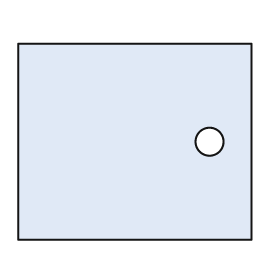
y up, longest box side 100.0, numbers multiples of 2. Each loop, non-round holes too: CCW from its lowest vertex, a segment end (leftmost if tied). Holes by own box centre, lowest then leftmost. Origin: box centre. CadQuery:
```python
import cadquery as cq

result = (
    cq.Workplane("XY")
    .moveTo(-50.0, -42.0)
    .lineTo(50.0, -42.0)
    .lineTo(50.0, 42.0)
    .lineTo(-50.0, 42.0)
    .close()
    .moveTo(32.0, 0.0)
    .circle(6.0)
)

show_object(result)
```